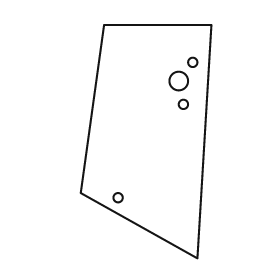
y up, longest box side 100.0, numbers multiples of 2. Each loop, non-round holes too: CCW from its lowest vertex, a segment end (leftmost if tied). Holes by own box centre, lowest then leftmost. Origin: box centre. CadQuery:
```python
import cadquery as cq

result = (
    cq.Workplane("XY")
    .moveTo(22.0, -50.0)
    .lineTo(28.0, 50.0)
    .lineTo(-18.0, 50.0)
    .lineTo(-28.0, -22.0)
    .close()
    .moveTo(-12.0, -24.0)
    .circle(2.0)
    .moveTo(16.0, 16.0)
    .circle(2.0)
    .moveTo(14.0, 26.0)
    .circle(4.0)
    .moveTo(20.0, 34.0)
    .circle(2.0)
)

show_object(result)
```